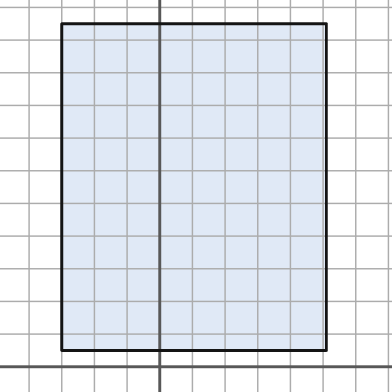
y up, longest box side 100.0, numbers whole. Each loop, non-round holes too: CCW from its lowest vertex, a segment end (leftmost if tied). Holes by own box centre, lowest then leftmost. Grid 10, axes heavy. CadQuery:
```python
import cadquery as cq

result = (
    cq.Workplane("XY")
    .moveTo(-30.0, 5.0)
    .lineTo(51.0, 5.0)
    .lineTo(51.0, 105.0)
    .lineTo(-30.0, 105.0)
    .close()
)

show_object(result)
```